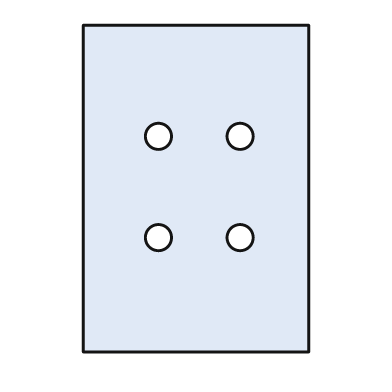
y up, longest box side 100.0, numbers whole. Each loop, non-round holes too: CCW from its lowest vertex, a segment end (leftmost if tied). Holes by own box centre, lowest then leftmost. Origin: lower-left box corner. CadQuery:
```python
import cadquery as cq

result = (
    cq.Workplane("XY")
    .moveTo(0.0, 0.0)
    .lineTo(69.0, 0.0)
    .lineTo(69.0, 100.0)
    .lineTo(0.0, 100.0)
    .close()
    .moveTo(23.0, 35.0)
    .circle(4.0)
    .moveTo(48.0, 35.0)
    .circle(4.0)
    .moveTo(23.0, 66.0)
    .circle(4.0)
    .moveTo(48.0, 66.0)
    .circle(4.0)
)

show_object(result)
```